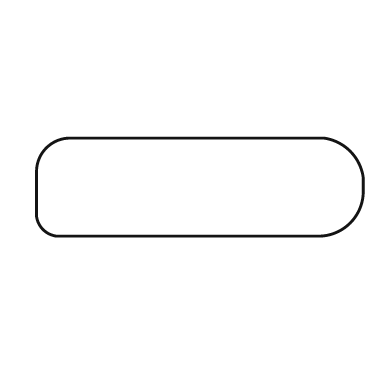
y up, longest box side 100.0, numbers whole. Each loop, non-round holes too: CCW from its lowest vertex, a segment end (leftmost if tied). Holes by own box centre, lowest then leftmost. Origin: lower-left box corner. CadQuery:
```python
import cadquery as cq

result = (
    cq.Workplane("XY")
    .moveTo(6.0, 0.0)
    .lineTo(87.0, 0.0)
    .threePointArc((96.0, 4.0), (100.0, 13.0))
    .lineTo(100.0, 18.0)
    .threePointArc((96.0, 26.0), (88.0, 30.0))
    .lineTo(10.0, 30.0)
    .threePointArc((3.0, 27.0), (0.0, 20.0))
    .lineTo(0.0, 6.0)
    .threePointArc((2.0, 2.0), (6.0, 0.0))
    .close()
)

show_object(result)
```